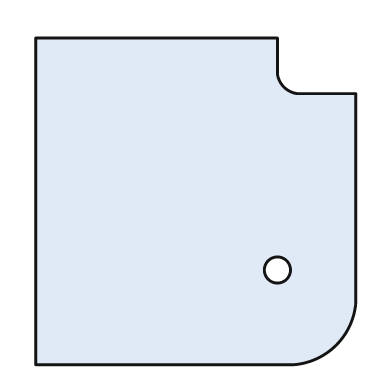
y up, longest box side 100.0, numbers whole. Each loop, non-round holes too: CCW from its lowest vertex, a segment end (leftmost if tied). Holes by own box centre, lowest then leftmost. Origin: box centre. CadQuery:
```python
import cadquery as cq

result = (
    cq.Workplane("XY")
    .moveTo(-49.0, -50.0)
    .lineTo(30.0, -50.0)
    .threePointArc((43.0, -44.0), (49.0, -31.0))
    .lineTo(49.0, 33.0)
    .lineTo(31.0, 33.0)
    .threePointArc((27.0, 35.0), (25.0, 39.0))
    .lineTo(25.0, 50.0)
    .lineTo(-49.0, 50.0)
    .close()
    .moveTo(25.0, -21.0)
    .circle(4.0)
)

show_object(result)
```